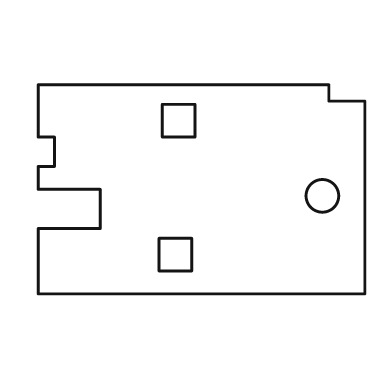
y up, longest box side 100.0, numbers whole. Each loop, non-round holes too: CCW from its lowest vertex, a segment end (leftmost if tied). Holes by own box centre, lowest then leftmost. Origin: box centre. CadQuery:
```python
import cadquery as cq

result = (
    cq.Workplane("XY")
    .moveTo(-50.0, -32.0)
    .lineTo(50.0, -32.0)
    .lineTo(50.0, 27.0)
    .lineTo(39.0, 27.0)
    .lineTo(39.0, 32.0)
    .lineTo(-50.0, 32.0)
    .lineTo(-50.0, 16.0)
    .lineTo(-45.0, 16.0)
    .lineTo(-45.0, 7.0)
    .lineTo(-50.0, 7.0)
    .lineTo(-50.0, 0.0)
    .lineTo(-31.0, 0.0)
    .lineTo(-31.0, -12.0)
    .lineTo(-50.0, -12.0)
    .close()
    .moveTo(-13.0, -25.0)
    .lineTo(-3.0, -25.0)
    .lineTo(-3.0, -15.0)
    .lineTo(-13.0, -15.0)
    .close()
    .moveTo(37.0, -2.0)
    .circle(5.0)
    .moveTo(-12.0, 16.0)
    .lineTo(-2.0, 16.0)
    .lineTo(-2.0, 26.0)
    .lineTo(-12.0, 26.0)
    .close()
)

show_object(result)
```